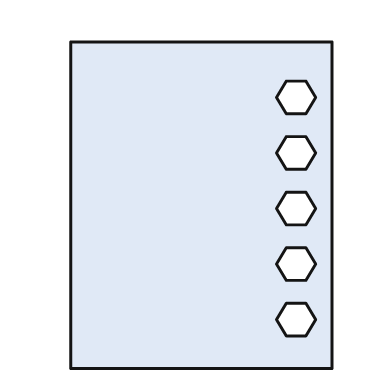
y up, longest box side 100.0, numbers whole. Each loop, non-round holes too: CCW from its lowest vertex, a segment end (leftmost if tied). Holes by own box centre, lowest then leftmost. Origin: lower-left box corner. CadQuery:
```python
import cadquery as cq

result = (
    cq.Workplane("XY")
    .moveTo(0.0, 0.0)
    .lineTo(80.0, 0.0)
    .lineTo(80.0, 100.0)
    .lineTo(0.0, 100.0)
    .close()
    .moveTo(66.0, 10.0)
    .lineTo(72.0, 10.0)
    .lineTo(75.0, 15.0)
    .lineTo(72.0, 20.0)
    .lineTo(66.0, 20.0)
    .lineTo(63.0, 15.0)
    .close()
    .moveTo(66.0, 27.0)
    .lineTo(72.0, 27.0)
    .lineTo(75.0, 32.0)
    .lineTo(72.0, 37.0)
    .lineTo(66.0, 37.0)
    .lineTo(63.0, 32.0)
    .close()
    .moveTo(66.0, 44.0)
    .lineTo(72.0, 44.0)
    .lineTo(75.0, 49.0)
    .lineTo(72.0, 54.0)
    .lineTo(66.0, 54.0)
    .lineTo(63.0, 49.0)
    .close()
    .moveTo(66.0, 61.0)
    .lineTo(72.0, 61.0)
    .lineTo(75.0, 66.0)
    .lineTo(72.0, 71.0)
    .lineTo(66.0, 71.0)
    .lineTo(63.0, 66.0)
    .close()
    .moveTo(66.0, 78.0)
    .lineTo(72.0, 78.0)
    .lineTo(75.0, 83.0)
    .lineTo(72.0, 88.0)
    .lineTo(66.0, 88.0)
    .lineTo(63.0, 83.0)
    .close()
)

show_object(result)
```